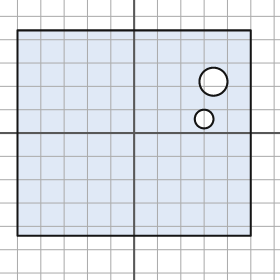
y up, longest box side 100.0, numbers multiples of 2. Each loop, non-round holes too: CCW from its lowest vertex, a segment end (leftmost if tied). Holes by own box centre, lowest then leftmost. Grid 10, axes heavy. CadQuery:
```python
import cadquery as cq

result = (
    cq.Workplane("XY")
    .moveTo(-50.0, -44.0)
    .lineTo(50.0, -44.0)
    .lineTo(50.0, 44.0)
    .lineTo(-50.0, 44.0)
    .close()
    .moveTo(30.0, 6.0)
    .circle(4.0)
    .moveTo(34.0, 22.0)
    .circle(6.0)
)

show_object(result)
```